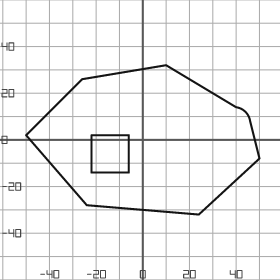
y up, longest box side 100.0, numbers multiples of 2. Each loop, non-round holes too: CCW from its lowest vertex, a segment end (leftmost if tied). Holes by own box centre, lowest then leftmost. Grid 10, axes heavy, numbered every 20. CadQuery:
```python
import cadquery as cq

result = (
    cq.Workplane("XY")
    .moveTo(24.0, -32.0)
    .lineTo(50.0, -8.0)
    .lineTo(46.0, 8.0)
    .threePointArc((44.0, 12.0), (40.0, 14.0))
    .lineTo(10.0, 32.0)
    .lineTo(-26.0, 26.0)
    .lineTo(-50.0, 2.0)
    .lineTo(-24.0, -28.0)
    .close()
    .moveTo(-22.0, -14.0)
    .lineTo(-6.0, -14.0)
    .lineTo(-6.0, 2.0)
    .lineTo(-22.0, 2.0)
    .close()
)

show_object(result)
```